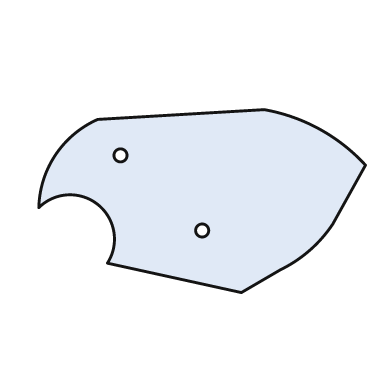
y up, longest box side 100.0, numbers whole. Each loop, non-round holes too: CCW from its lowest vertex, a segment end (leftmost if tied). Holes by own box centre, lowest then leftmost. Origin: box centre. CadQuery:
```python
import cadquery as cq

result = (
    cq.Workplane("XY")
    .moveTo(12.0, -28.0)
    .lineTo(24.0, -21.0)
    .threePointArc((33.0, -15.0), (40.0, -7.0))
    .lineTo(50.0, 11.0)
    .threePointArc((36.0, 22.0), (19.0, 28.0))
    .lineTo(-32.0, 25.0)
    .threePointArc((-45.0, 14.0), (-50.0, -2.0))
    .threePointArc((-32.0, -1.0), (-29.0, -19.0))
    .close()
    .moveTo(0.0, -9.0)
    .circle(2.0)
    .moveTo(-25.0, 14.0)
    .circle(2.0)
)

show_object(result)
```